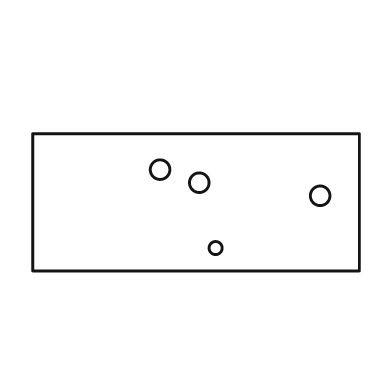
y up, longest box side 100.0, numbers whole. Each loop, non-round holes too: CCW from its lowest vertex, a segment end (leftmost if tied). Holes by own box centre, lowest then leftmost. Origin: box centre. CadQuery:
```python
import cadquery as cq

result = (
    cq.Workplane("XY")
    .moveTo(-50.0, -21.0)
    .lineTo(50.0, -21.0)
    .lineTo(50.0, 21.0)
    .lineTo(-50.0, 21.0)
    .close()
    .moveTo(6.0, -14.0)
    .circle(2.0)
    .moveTo(38.0, 2.0)
    .circle(3.0)
    .moveTo(1.0, 6.0)
    .circle(3.0)
    .moveTo(-11.0, 10.0)
    .circle(3.0)
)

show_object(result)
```